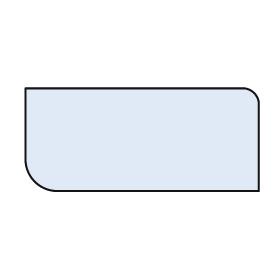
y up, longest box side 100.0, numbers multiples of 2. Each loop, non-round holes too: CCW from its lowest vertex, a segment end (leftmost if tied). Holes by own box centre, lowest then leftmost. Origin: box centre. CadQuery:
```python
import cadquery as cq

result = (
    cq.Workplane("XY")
    .moveTo(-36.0, -22.0)
    .lineTo(50.0, -22.0)
    .lineTo(50.0, 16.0)
    .threePointArc((48.0, 20.0), (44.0, 22.0))
    .lineTo(-50.0, 22.0)
    .lineTo(-50.0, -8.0)
    .threePointArc((-46.0, -18.0), (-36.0, -22.0))
    .close()
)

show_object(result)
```